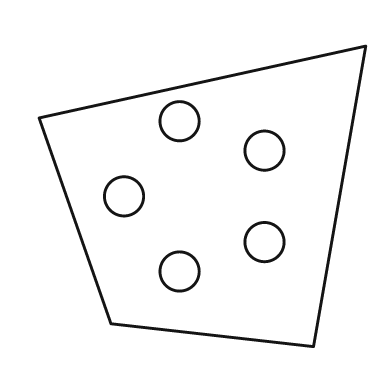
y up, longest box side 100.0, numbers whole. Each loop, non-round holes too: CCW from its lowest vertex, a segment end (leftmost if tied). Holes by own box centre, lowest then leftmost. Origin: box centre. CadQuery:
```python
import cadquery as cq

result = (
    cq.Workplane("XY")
    .moveTo(34.0, -46.0)
    .lineTo(50.0, 46.0)
    .lineTo(-50.0, 24.0)
    .lineTo(-28.0, -39.0)
    .close()
    .moveTo(-7.0, -23.0)
    .circle(6.0)
    .moveTo(19.0, -14.0)
    .circle(6.0)
    .moveTo(-24.0, 0.0)
    .circle(6.0)
    .moveTo(19.0, 14.0)
    .circle(6.0)
    .moveTo(-7.0, 23.0)
    .circle(6.0)
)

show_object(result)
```